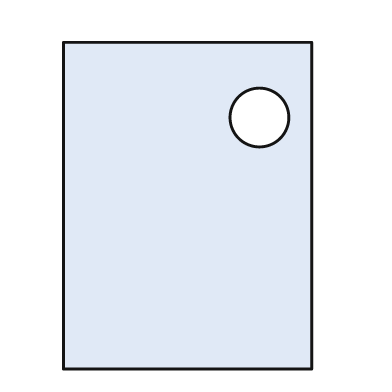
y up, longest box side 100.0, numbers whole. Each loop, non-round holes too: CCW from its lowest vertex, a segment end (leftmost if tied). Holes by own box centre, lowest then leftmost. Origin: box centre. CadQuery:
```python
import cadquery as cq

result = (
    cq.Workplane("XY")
    .moveTo(-38.0, -50.0)
    .lineTo(38.0, -50.0)
    .lineTo(38.0, 50.0)
    .lineTo(-38.0, 50.0)
    .close()
    .moveTo(22.0, 27.0)
    .circle(9.0)
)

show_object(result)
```